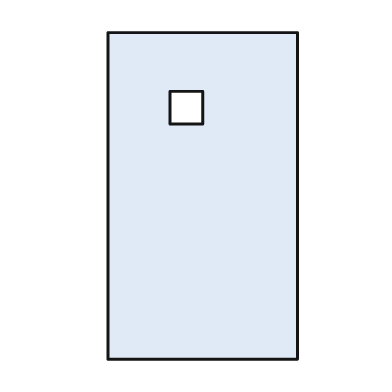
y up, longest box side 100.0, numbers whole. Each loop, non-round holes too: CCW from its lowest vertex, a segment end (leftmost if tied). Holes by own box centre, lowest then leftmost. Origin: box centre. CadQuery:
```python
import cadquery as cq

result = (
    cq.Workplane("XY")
    .moveTo(-29.0, -50.0)
    .lineTo(29.0, -50.0)
    .lineTo(29.0, 50.0)
    .lineTo(-29.0, 50.0)
    .close()
    .moveTo(-10.0, 22.0)
    .lineTo(0.0, 22.0)
    .lineTo(0.0, 32.0)
    .lineTo(-10.0, 32.0)
    .close()
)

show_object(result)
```